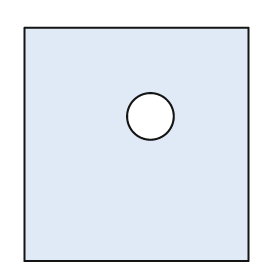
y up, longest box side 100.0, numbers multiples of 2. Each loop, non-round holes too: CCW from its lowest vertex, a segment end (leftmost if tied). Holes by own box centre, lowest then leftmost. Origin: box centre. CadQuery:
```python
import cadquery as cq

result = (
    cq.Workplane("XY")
    .moveTo(-48.0, -50.0)
    .lineTo(48.0, -50.0)
    .lineTo(48.0, 50.0)
    .lineTo(-48.0, 50.0)
    .close()
    .moveTo(6.0, 12.0)
    .circle(10.0)
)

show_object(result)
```